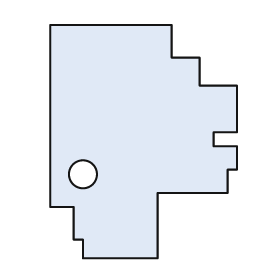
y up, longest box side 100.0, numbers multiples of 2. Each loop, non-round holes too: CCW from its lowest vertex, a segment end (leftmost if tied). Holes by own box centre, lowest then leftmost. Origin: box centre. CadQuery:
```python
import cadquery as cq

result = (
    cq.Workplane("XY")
    .moveTo(-26.0, -50.0)
    .lineTo(6.0, -50.0)
    .lineTo(6.0, -22.0)
    .lineTo(36.0, -22.0)
    .lineTo(36.0, -12.0)
    .lineTo(40.0, -12.0)
    .lineTo(40.0, -2.0)
    .lineTo(30.0, -2.0)
    .lineTo(30.0, 4.0)
    .lineTo(40.0, 4.0)
    .lineTo(40.0, 24.0)
    .lineTo(24.0, 24.0)
    .lineTo(24.0, 36.0)
    .lineTo(12.0, 36.0)
    .lineTo(12.0, 50.0)
    .lineTo(-40.0, 50.0)
    .lineTo(-40.0, -28.0)
    .lineTo(-30.0, -28.0)
    .lineTo(-30.0, -42.0)
    .lineTo(-26.0, -42.0)
    .close()
    .moveTo(-26.0, -14.0)
    .circle(6.0)
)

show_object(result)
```